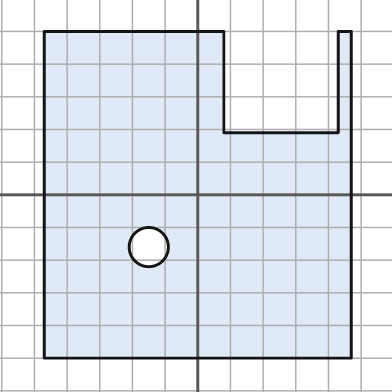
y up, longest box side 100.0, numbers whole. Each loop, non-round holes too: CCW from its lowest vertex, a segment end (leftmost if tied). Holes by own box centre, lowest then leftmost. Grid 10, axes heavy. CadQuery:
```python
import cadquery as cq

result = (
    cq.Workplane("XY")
    .moveTo(-47.0, -50.0)
    .lineTo(47.0, -50.0)
    .lineTo(47.0, 50.0)
    .lineTo(43.0, 50.0)
    .lineTo(43.0, 19.0)
    .lineTo(8.0, 19.0)
    .lineTo(8.0, 50.0)
    .lineTo(-47.0, 50.0)
    .close()
    .moveTo(-15.0, -16.0)
    .circle(6.0)
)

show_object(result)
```